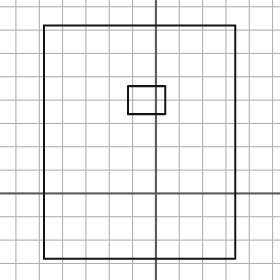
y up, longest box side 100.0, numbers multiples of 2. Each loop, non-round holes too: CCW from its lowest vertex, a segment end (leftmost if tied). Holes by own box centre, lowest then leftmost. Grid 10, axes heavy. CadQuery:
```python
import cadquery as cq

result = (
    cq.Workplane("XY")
    .moveTo(-48.0, -28.0)
    .lineTo(34.0, -28.0)
    .lineTo(34.0, 72.0)
    .lineTo(-48.0, 72.0)
    .close()
    .moveTo(-12.0, 34.0)
    .lineTo(4.0, 34.0)
    .lineTo(4.0, 46.0)
    .lineTo(-12.0, 46.0)
    .close()
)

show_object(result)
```